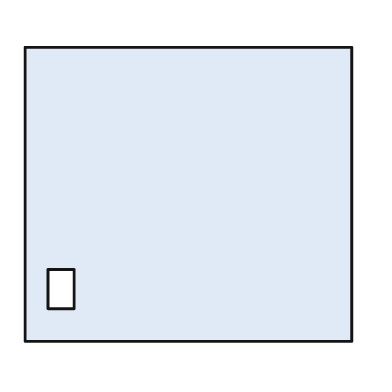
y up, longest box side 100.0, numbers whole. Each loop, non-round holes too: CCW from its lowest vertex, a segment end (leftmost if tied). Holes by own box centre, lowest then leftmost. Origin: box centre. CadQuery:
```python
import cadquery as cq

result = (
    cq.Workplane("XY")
    .moveTo(-50.0, -45.0)
    .lineTo(50.0, -45.0)
    .lineTo(50.0, 45.0)
    .lineTo(-50.0, 45.0)
    .close()
    .moveTo(-43.0, -35.0)
    .lineTo(-35.0, -35.0)
    .lineTo(-35.0, -23.0)
    .lineTo(-43.0, -23.0)
    .close()
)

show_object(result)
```